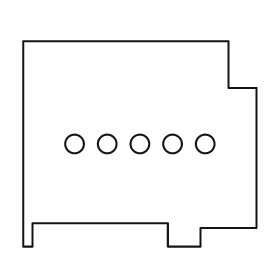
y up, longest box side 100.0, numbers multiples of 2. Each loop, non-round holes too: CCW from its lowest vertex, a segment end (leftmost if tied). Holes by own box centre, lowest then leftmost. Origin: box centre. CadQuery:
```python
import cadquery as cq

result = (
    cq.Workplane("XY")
    .moveTo(-50.0, -44.0)
    .lineTo(-46.0, -44.0)
    .lineTo(-46.0, -34.0)
    .lineTo(12.0, -34.0)
    .lineTo(12.0, -44.0)
    .lineTo(26.0, -44.0)
    .lineTo(26.0, -36.0)
    .lineTo(50.0, -36.0)
    .lineTo(50.0, 24.0)
    .lineTo(38.0, 24.0)
    .lineTo(38.0, 44.0)
    .lineTo(-50.0, 44.0)
    .close()
    .moveTo(-28.0, 0.0)
    .circle(4.0)
    .moveTo(-14.0, 0.0)
    .circle(4.0)
    .moveTo(0.0, 0.0)
    .circle(4.0)
    .moveTo(14.0, 0.0)
    .circle(4.0)
    .moveTo(28.0, 0.0)
    .circle(4.0)
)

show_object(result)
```